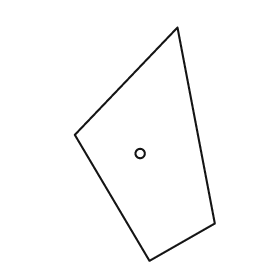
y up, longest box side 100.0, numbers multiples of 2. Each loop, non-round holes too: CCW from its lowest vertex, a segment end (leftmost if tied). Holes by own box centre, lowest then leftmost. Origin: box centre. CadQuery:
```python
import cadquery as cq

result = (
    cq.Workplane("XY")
    .moveTo(2.0, -50.0)
    .lineTo(30.0, -34.0)
    .lineTo(14.0, 50.0)
    .lineTo(-30.0, 4.0)
    .close()
    .moveTo(-2.0, -4.0)
    .circle(2.0)
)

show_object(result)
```